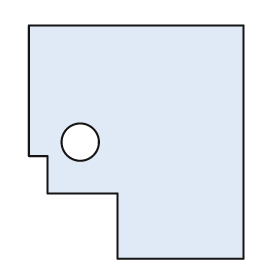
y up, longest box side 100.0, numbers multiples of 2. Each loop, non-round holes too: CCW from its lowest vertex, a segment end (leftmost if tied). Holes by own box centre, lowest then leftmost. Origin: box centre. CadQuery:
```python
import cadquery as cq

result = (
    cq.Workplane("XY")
    .moveTo(-8.0, -50.0)
    .lineTo(46.0, -50.0)
    .lineTo(46.0, 50.0)
    .lineTo(-46.0, 50.0)
    .lineTo(-46.0, -6.0)
    .lineTo(-38.0, -6.0)
    .lineTo(-38.0, -22.0)
    .lineTo(-8.0, -22.0)
    .close()
    .moveTo(-24.0, 0.0)
    .circle(8.0)
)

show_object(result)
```